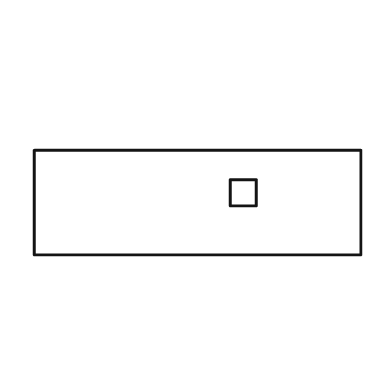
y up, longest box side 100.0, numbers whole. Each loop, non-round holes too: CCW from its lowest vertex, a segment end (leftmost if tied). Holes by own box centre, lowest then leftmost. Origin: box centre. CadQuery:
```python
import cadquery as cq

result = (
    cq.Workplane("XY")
    .moveTo(-50.0, -16.0)
    .lineTo(50.0, -16.0)
    .lineTo(50.0, 16.0)
    .lineTo(-50.0, 16.0)
    .close()
    .moveTo(10.0, -1.0)
    .lineTo(18.0, -1.0)
    .lineTo(18.0, 7.0)
    .lineTo(10.0, 7.0)
    .close()
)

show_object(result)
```